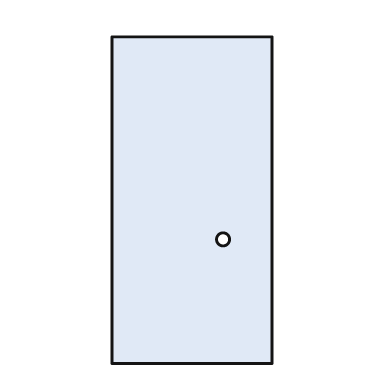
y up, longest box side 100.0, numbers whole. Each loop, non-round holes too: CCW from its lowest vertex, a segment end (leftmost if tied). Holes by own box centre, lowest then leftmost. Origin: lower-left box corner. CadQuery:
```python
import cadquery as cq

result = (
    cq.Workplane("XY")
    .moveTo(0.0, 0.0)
    .lineTo(49.0, 0.0)
    .lineTo(49.0, 100.0)
    .lineTo(0.0, 100.0)
    .close()
    .moveTo(34.0, 38.0)
    .circle(2.0)
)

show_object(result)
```